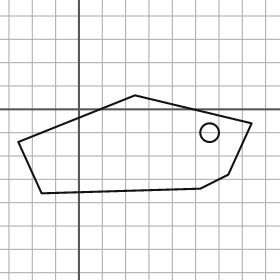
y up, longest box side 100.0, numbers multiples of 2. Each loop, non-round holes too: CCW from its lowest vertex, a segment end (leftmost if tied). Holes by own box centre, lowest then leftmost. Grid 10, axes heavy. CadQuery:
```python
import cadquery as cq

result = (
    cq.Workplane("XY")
    .moveTo(-16.0, -36.0)
    .lineTo(52.0, -34.0)
    .lineTo(64.0, -28.0)
    .lineTo(74.0, -6.0)
    .lineTo(24.0, 6.0)
    .lineTo(-26.0, -14.0)
    .close()
    .moveTo(56.0, -10.0)
    .circle(4.0)
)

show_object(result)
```